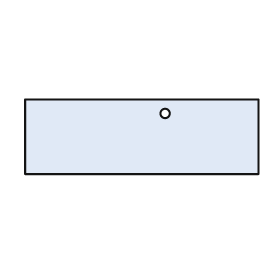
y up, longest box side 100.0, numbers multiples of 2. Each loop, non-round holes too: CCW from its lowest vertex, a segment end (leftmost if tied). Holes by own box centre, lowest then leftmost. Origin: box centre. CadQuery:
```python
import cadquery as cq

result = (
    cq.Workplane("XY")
    .moveTo(-50.0, -16.0)
    .lineTo(50.0, -16.0)
    .lineTo(50.0, 16.0)
    .lineTo(-50.0, 16.0)
    .close()
    .moveTo(10.0, 10.0)
    .circle(2.0)
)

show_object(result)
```